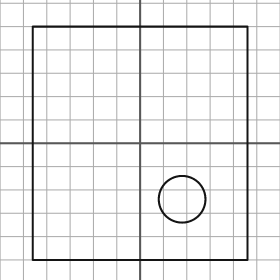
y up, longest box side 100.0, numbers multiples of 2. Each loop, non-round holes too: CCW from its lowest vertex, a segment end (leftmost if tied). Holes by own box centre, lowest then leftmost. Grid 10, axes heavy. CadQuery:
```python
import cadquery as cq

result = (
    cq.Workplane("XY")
    .moveTo(-46.0, -50.0)
    .lineTo(46.0, -50.0)
    .lineTo(46.0, 50.0)
    .lineTo(-46.0, 50.0)
    .close()
    .moveTo(18.0, -24.0)
    .circle(10.0)
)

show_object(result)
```